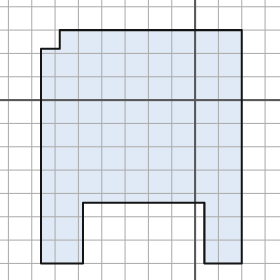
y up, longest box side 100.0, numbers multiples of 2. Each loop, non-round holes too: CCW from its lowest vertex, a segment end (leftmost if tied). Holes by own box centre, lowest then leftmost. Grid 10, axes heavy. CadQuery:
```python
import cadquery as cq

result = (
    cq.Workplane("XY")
    .moveTo(-66.0, -70.0)
    .lineTo(-48.0, -70.0)
    .lineTo(-48.0, -44.0)
    .lineTo(4.0, -44.0)
    .lineTo(4.0, -70.0)
    .lineTo(20.0, -70.0)
    .lineTo(20.0, 30.0)
    .lineTo(-58.0, 30.0)
    .lineTo(-58.0, 22.0)
    .lineTo(-66.0, 22.0)
    .close()
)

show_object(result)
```